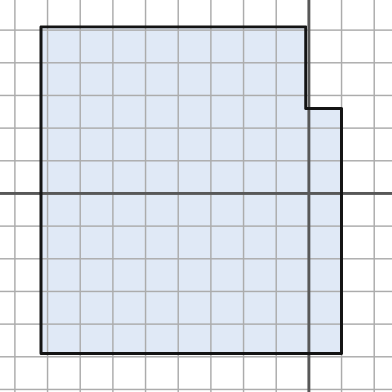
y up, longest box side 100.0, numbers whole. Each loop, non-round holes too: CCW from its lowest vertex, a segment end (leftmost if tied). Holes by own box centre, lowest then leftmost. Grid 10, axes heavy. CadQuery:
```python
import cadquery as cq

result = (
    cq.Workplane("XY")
    .moveTo(-82.0, -49.0)
    .lineTo(10.0, -49.0)
    .lineTo(10.0, 26.0)
    .lineTo(-1.0, 26.0)
    .lineTo(-1.0, 51.0)
    .lineTo(-82.0, 51.0)
    .close()
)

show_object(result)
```